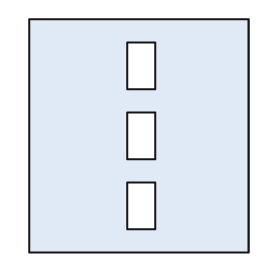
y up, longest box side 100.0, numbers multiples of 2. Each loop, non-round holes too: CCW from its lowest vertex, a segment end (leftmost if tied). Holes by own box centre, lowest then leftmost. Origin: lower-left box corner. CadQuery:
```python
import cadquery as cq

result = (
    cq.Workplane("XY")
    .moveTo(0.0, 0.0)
    .lineTo(94.0, 0.0)
    .lineTo(94.0, 100.0)
    .lineTo(0.0, 100.0)
    .close()
    .moveTo(42.0, 10.0)
    .lineTo(54.0, 10.0)
    .lineTo(54.0, 30.0)
    .lineTo(42.0, 30.0)
    .close()
    .moveTo(42.0, 40.0)
    .lineTo(54.0, 40.0)
    .lineTo(54.0, 60.0)
    .lineTo(42.0, 60.0)
    .close()
    .moveTo(42.0, 70.0)
    .lineTo(54.0, 70.0)
    .lineTo(54.0, 90.0)
    .lineTo(42.0, 90.0)
    .close()
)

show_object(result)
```